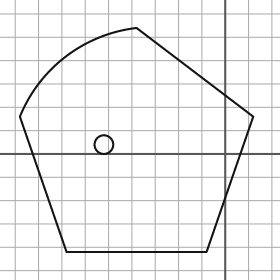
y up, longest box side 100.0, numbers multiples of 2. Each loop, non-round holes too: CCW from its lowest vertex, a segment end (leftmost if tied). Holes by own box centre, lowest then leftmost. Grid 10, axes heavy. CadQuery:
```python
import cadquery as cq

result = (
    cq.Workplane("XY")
    .moveTo(-68.0, -42.0)
    .lineTo(-8.0, -42.0)
    .lineTo(12.0, 16.0)
    .lineTo(-38.0, 54.0)
    .threePointArc((-68.0, 42.0), (-88.0, 16.0))
    .close()
    .moveTo(-52.0, 4.0)
    .circle(4.0)
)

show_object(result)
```